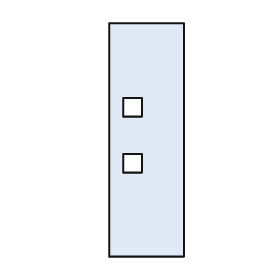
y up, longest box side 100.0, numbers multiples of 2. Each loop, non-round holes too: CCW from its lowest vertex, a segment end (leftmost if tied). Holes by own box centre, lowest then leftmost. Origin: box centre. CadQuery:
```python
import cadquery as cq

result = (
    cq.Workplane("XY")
    .moveTo(-16.0, -50.0)
    .lineTo(16.0, -50.0)
    .lineTo(16.0, 50.0)
    .lineTo(-16.0, 50.0)
    .close()
    .moveTo(-10.0, -14.0)
    .lineTo(-2.0, -14.0)
    .lineTo(-2.0, -6.0)
    .lineTo(-10.0, -6.0)
    .close()
    .moveTo(-10.0, 10.0)
    .lineTo(-2.0, 10.0)
    .lineTo(-2.0, 18.0)
    .lineTo(-10.0, 18.0)
    .close()
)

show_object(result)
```